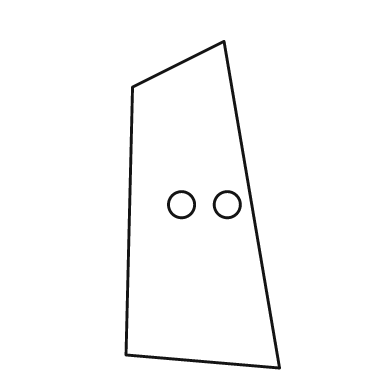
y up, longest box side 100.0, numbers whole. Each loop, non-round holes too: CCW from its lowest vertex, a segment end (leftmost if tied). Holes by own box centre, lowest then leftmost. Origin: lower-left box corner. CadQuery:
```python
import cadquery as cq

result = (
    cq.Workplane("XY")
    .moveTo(47.0, 0.0)
    .lineTo(30.0, 100.0)
    .lineTo(2.0, 86.0)
    .lineTo(0.0, 4.0)
    .close()
    .moveTo(17.0, 50.0)
    .circle(4.0)
    .moveTo(31.0, 50.0)
    .circle(4.0)
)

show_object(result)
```